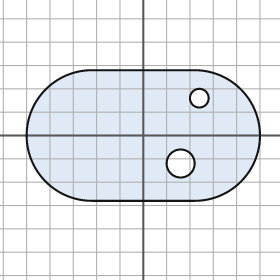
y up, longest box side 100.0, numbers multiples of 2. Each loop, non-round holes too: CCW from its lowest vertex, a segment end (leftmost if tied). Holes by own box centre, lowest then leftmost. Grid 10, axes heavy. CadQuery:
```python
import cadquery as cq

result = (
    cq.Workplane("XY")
    .moveTo(-22.0, -28.0)
    .lineTo(22.0, -28.0)
    .threePointArc((50.0, 0.0), (22.0, 28.0))
    .lineTo(-22.0, 28.0)
    .threePointArc((-50.0, 0.0), (-22.0, -28.0))
    .close()
    .moveTo(16.0, -12.0)
    .circle(6.0)
    .moveTo(24.0, 16.0)
    .circle(4.0)
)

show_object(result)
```